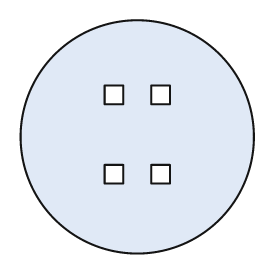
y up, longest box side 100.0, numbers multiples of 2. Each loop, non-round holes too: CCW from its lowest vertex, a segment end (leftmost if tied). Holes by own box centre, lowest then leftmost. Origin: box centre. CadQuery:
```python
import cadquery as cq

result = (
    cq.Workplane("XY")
    .moveTo(0.0, 0.0)
    .circle(50.0)
    .moveTo(-14.0, -20.0)
    .lineTo(-6.0, -20.0)
    .lineTo(-6.0, -12.0)
    .lineTo(-14.0, -12.0)
    .close()
    .moveTo(6.0, -20.0)
    .lineTo(14.0, -20.0)
    .lineTo(14.0, -12.0)
    .lineTo(6.0, -12.0)
    .close()
    .moveTo(-14.0, 14.0)
    .lineTo(-6.0, 14.0)
    .lineTo(-6.0, 22.0)
    .lineTo(-14.0, 22.0)
    .close()
    .moveTo(6.0, 14.0)
    .lineTo(14.0, 14.0)
    .lineTo(14.0, 22.0)
    .lineTo(6.0, 22.0)
    .close()
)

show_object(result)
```